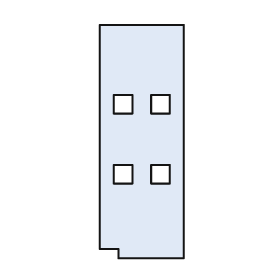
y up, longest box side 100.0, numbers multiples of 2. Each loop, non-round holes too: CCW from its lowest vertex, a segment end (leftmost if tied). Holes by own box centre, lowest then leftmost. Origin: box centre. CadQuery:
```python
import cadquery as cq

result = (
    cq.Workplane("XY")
    .moveTo(-10.0, -50.0)
    .lineTo(18.0, -50.0)
    .lineTo(18.0, 50.0)
    .lineTo(-18.0, 50.0)
    .lineTo(-18.0, -46.0)
    .lineTo(-10.0, -46.0)
    .close()
    .moveTo(-12.0, -18.0)
    .lineTo(-4.0, -18.0)
    .lineTo(-4.0, -10.0)
    .lineTo(-12.0, -10.0)
    .close()
    .moveTo(4.0, -18.0)
    .lineTo(12.0, -18.0)
    .lineTo(12.0, -10.0)
    .lineTo(4.0, -10.0)
    .close()
    .moveTo(-12.0, 12.0)
    .lineTo(-4.0, 12.0)
    .lineTo(-4.0, 20.0)
    .lineTo(-12.0, 20.0)
    .close()
    .moveTo(4.0, 12.0)
    .lineTo(12.0, 12.0)
    .lineTo(12.0, 20.0)
    .lineTo(4.0, 20.0)
    .close()
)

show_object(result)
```